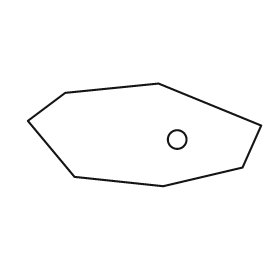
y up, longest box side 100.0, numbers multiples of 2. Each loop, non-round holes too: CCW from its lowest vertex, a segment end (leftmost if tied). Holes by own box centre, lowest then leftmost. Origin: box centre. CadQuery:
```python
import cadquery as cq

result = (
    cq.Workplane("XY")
    .moveTo(8.0, -22.0)
    .lineTo(42.0, -14.0)
    .lineTo(50.0, 4.0)
    .lineTo(6.0, 22.0)
    .lineTo(-34.0, 18.0)
    .lineTo(-50.0, 6.0)
    .lineTo(-30.0, -18.0)
    .close()
    .moveTo(14.0, -2.0)
    .circle(4.0)
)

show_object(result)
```